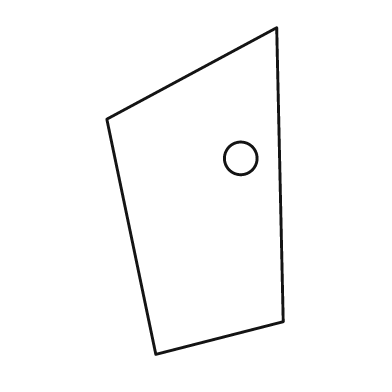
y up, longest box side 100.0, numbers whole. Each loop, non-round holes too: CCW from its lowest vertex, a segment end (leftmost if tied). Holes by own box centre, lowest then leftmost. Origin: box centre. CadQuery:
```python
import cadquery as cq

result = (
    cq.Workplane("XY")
    .moveTo(-12.0, -50.0)
    .lineTo(27.0, -40.0)
    .lineTo(25.0, 50.0)
    .lineTo(-27.0, 22.0)
    .close()
    .moveTo(14.0, 10.0)
    .circle(5.0)
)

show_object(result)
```